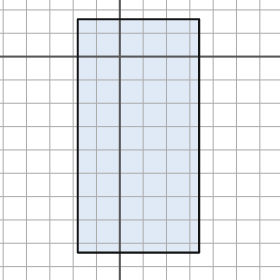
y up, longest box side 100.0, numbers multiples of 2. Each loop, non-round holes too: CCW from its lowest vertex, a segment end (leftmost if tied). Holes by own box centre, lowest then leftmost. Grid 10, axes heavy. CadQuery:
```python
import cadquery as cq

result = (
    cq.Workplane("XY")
    .moveTo(-18.0, -84.0)
    .lineTo(34.0, -84.0)
    .lineTo(34.0, 16.0)
    .lineTo(-18.0, 16.0)
    .close()
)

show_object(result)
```